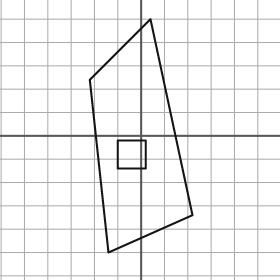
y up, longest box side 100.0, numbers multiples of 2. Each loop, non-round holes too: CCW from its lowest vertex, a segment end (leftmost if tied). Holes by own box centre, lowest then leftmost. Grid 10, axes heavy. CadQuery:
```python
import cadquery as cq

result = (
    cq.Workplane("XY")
    .moveTo(-14.0, -50.0)
    .lineTo(22.0, -34.0)
    .lineTo(4.0, 50.0)
    .lineTo(-22.0, 24.0)
    .close()
    .moveTo(-10.0, -14.0)
    .lineTo(2.0, -14.0)
    .lineTo(2.0, -2.0)
    .lineTo(-10.0, -2.0)
    .close()
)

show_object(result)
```